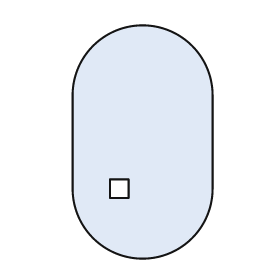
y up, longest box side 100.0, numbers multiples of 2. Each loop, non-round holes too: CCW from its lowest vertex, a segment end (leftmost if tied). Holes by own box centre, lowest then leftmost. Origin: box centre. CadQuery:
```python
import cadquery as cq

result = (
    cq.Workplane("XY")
    .moveTo(-30.0, -20.0)
    .threePointArc((0.0, -50.0), (30.0, -20.0))
    .lineTo(30.0, 20.0)
    .threePointArc((0.0, 50.0), (-30.0, 20.0))
    .close()
    .moveTo(-14.0, -24.0)
    .lineTo(-6.0, -24.0)
    .lineTo(-6.0, -16.0)
    .lineTo(-14.0, -16.0)
    .close()
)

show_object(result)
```